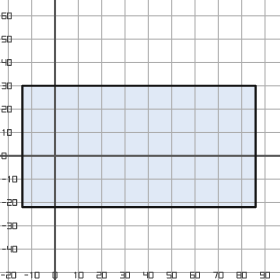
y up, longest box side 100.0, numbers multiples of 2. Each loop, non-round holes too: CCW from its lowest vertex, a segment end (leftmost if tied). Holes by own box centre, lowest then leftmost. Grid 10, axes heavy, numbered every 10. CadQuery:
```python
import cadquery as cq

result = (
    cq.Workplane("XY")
    .moveTo(-14.0, -22.0)
    .lineTo(86.0, -22.0)
    .lineTo(86.0, 30.0)
    .lineTo(-14.0, 30.0)
    .close()
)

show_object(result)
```